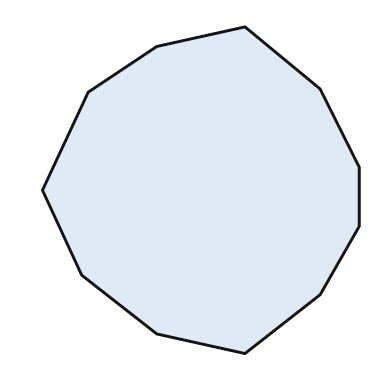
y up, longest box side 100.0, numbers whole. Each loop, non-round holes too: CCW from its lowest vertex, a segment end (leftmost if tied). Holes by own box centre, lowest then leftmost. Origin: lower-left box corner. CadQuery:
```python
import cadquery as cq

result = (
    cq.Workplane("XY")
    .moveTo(62.0, 0.0)
    .lineTo(85.0, 18.0)
    .lineTo(97.0, 39.0)
    .lineTo(97.0, 57.0)
    .lineTo(85.0, 81.0)
    .lineTo(62.0, 100.0)
    .lineTo(35.0, 94.0)
    .lineTo(14.0, 80.0)
    .lineTo(0.0, 50.0)
    .lineTo(12.0, 24.0)
    .lineTo(35.0, 6.0)
    .close()
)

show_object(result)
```